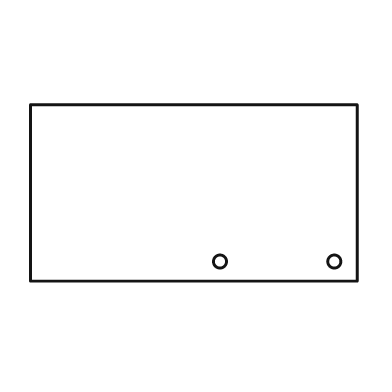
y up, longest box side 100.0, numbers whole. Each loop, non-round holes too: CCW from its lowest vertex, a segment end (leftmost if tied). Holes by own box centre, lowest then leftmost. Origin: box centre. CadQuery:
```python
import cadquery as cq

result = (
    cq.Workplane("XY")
    .moveTo(-50.0, -27.0)
    .lineTo(50.0, -27.0)
    .lineTo(50.0, 27.0)
    .lineTo(-50.0, 27.0)
    .close()
    .moveTo(8.0, -21.0)
    .circle(2.0)
    .moveTo(43.0, -21.0)
    .circle(2.0)
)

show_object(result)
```